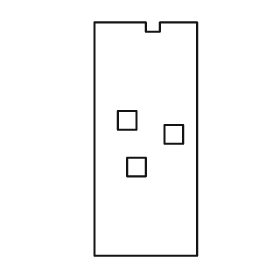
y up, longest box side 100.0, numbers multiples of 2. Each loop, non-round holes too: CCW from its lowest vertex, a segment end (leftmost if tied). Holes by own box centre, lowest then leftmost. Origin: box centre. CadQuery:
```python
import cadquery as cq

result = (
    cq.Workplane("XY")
    .moveTo(-22.0, -50.0)
    .lineTo(22.0, -50.0)
    .lineTo(22.0, 50.0)
    .lineTo(6.0, 50.0)
    .lineTo(6.0, 46.0)
    .lineTo(0.0, 46.0)
    .lineTo(0.0, 50.0)
    .lineTo(-22.0, 50.0)
    .close()
    .moveTo(-8.0, -16.0)
    .lineTo(0.0, -16.0)
    .lineTo(0.0, -8.0)
    .lineTo(-8.0, -8.0)
    .close()
    .moveTo(8.0, -2.0)
    .lineTo(16.0, -2.0)
    .lineTo(16.0, 6.0)
    .lineTo(8.0, 6.0)
    .close()
    .moveTo(-12.0, 4.0)
    .lineTo(-4.0, 4.0)
    .lineTo(-4.0, 12.0)
    .lineTo(-12.0, 12.0)
    .close()
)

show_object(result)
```